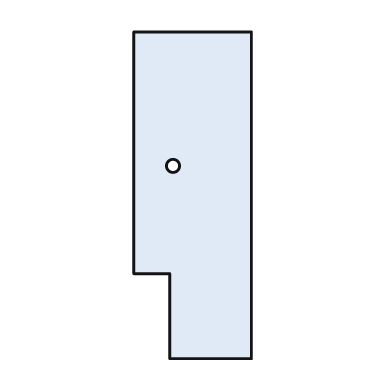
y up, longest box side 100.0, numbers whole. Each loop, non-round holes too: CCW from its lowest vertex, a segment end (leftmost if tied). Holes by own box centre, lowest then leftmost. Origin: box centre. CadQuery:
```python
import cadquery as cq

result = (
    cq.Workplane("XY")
    .moveTo(-7.0, -50.0)
    .lineTo(18.0, -50.0)
    .lineTo(18.0, 50.0)
    .lineTo(-18.0, 50.0)
    .lineTo(-18.0, -24.0)
    .lineTo(-7.0, -24.0)
    .close()
    .moveTo(-6.0, 9.0)
    .circle(2.0)
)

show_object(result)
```